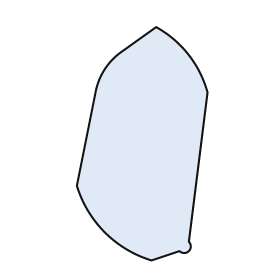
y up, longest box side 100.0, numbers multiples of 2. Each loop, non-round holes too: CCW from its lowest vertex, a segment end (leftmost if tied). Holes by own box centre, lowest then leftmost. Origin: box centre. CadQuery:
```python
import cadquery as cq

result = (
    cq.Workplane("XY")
    .moveTo(4.0, -50.0)
    .lineTo(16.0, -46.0)
    .threePointArc((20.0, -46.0), (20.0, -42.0))
    .lineTo(28.0, 22.0)
    .threePointArc((20.0, 38.0), (6.0, 50.0))
    .lineTo(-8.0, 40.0)
    .threePointArc((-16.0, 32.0), (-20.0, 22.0))
    .lineTo(-28.0, -18.0)
    .threePointArc((-16.0, -38.0), (4.0, -50.0))
    .close()
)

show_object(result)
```